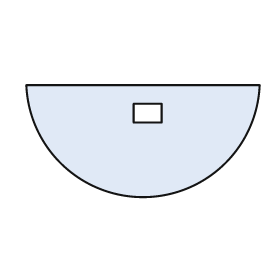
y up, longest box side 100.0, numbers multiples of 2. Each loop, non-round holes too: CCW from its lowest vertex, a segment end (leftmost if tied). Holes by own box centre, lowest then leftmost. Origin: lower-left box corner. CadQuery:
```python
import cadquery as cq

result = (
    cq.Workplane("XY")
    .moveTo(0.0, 48.0)
    .threePointArc((50.0, 0.0), (100.0, 48.0))
    .close()
    .moveTo(46.0, 32.0)
    .lineTo(58.0, 32.0)
    .lineTo(58.0, 40.0)
    .lineTo(46.0, 40.0)
    .close()
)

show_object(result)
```